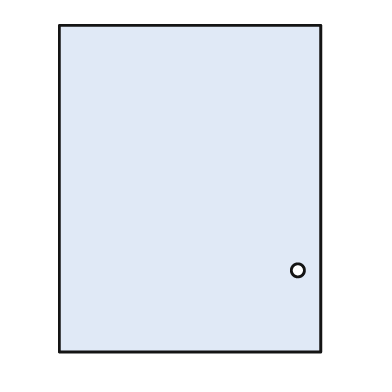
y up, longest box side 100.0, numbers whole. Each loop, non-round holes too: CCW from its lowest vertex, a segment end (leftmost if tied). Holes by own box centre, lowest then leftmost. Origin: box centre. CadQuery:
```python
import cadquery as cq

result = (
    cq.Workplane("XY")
    .moveTo(-40.0, -50.0)
    .lineTo(40.0, -50.0)
    .lineTo(40.0, 50.0)
    .lineTo(-40.0, 50.0)
    .close()
    .moveTo(33.0, -25.0)
    .circle(2.0)
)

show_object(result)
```